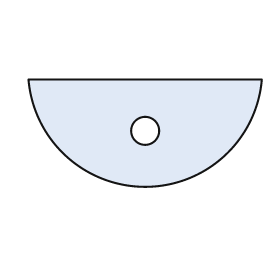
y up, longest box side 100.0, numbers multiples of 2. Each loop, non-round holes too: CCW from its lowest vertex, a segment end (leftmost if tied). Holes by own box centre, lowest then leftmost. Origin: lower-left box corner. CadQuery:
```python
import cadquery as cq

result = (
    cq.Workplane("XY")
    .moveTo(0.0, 46.0)
    .threePointArc((50.0, 0.0), (100.0, 46.0))
    .close()
    .moveTo(50.0, 24.0)
    .circle(6.0)
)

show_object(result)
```